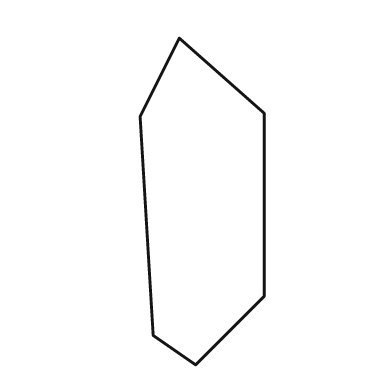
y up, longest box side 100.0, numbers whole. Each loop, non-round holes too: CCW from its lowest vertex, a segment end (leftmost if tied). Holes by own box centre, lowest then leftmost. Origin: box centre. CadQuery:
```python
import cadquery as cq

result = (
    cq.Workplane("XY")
    .moveTo(-2.0, -50.0)
    .lineTo(19.0, -29.0)
    .lineTo(19.0, 27.0)
    .lineTo(-7.0, 50.0)
    .lineTo(-19.0, 26.0)
    .lineTo(-15.0, -41.0)
    .close()
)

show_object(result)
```